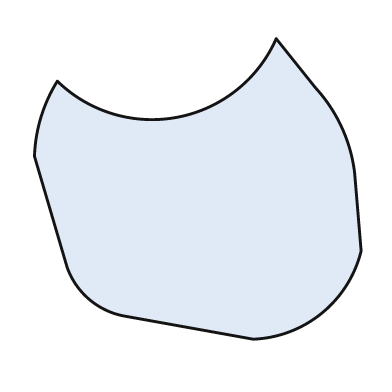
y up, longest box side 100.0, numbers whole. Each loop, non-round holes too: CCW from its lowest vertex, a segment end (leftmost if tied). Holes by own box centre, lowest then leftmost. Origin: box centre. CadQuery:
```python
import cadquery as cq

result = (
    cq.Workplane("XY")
    .moveTo(17.0, -46.0)
    .threePointArc((38.0, -38.0), (50.0, -19.0))
    .lineTo(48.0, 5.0)
    .threePointArc((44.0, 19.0), (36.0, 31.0))
    .lineTo(24.0, 46.0)
    .threePointArc((-6.0, 22.0), (-43.0, 33.0))
    .threePointArc((-48.0, 22.0), (-50.0, 10.0))
    .lineTo(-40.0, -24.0)
    .threePointArc((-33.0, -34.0), (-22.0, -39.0))
    .close()
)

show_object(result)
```